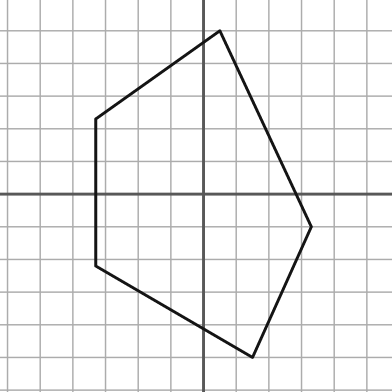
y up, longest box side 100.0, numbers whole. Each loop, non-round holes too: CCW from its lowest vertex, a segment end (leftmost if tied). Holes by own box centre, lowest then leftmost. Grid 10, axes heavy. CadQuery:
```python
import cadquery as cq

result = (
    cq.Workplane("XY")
    .moveTo(15.0, -50.0)
    .lineTo(33.0, -10.0)
    .lineTo(5.0, 50.0)
    .lineTo(-33.0, 23.0)
    .lineTo(-33.0, -22.0)
    .close()
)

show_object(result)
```